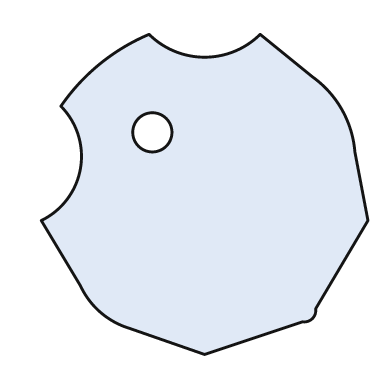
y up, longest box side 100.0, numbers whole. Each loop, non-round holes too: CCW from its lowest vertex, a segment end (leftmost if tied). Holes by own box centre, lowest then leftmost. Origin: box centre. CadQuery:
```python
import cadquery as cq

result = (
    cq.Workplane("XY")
    .moveTo(0.0, -49.0)
    .lineTo(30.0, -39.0)
    .threePointArc((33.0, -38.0), (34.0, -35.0))
    .lineTo(50.0, -8.0)
    .lineTo(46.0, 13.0)
    .threePointArc((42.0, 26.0), (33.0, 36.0))
    .lineTo(17.0, 49.0)
    .threePointArc((0.0, 42.0), (-17.0, 49.0))
    .threePointArc((-32.0, 40.0), (-44.0, 27.0))
    .threePointArc((-38.0, 8.0), (-50.0, -8.0))
    .lineTo(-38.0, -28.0)
    .threePointArc((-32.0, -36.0), (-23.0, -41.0))
    .close()
    .moveTo(-16.0, 19.0)
    .circle(6.0)
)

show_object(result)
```